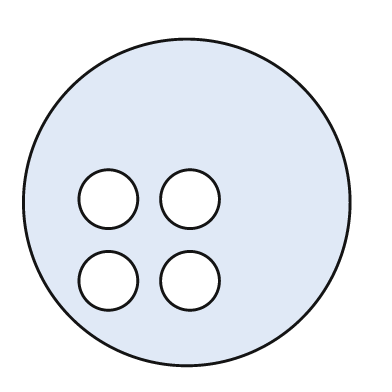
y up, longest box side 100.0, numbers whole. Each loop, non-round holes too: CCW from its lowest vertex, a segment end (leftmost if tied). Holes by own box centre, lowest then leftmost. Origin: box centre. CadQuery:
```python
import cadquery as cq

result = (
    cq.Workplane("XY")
    .moveTo(0.0, 0.0)
    .circle(50.0)
    .moveTo(-24.0, -24.0)
    .circle(9.0)
    .moveTo(1.0, -24.0)
    .circle(9.0)
    .moveTo(-24.0, 1.0)
    .circle(9.0)
    .moveTo(1.0, 1.0)
    .circle(9.0)
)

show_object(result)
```